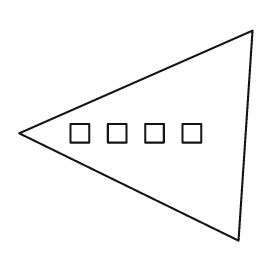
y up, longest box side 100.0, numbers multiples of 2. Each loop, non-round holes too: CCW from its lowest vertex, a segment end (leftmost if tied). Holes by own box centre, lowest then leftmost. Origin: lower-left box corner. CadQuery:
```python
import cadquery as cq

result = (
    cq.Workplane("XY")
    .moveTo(94.0, 0.0)
    .lineTo(100.0, 90.0)
    .lineTo(0.0, 46.0)
    .close()
    .moveTo(22.0, 42.0)
    .lineTo(30.0, 42.0)
    .lineTo(30.0, 50.0)
    .lineTo(22.0, 50.0)
    .close()
    .moveTo(38.0, 42.0)
    .lineTo(46.0, 42.0)
    .lineTo(46.0, 50.0)
    .lineTo(38.0, 50.0)
    .close()
    .moveTo(54.0, 42.0)
    .lineTo(62.0, 42.0)
    .lineTo(62.0, 50.0)
    .lineTo(54.0, 50.0)
    .close()
    .moveTo(70.0, 42.0)
    .lineTo(78.0, 42.0)
    .lineTo(78.0, 50.0)
    .lineTo(70.0, 50.0)
    .close()
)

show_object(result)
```